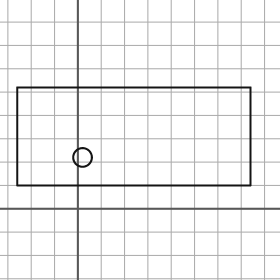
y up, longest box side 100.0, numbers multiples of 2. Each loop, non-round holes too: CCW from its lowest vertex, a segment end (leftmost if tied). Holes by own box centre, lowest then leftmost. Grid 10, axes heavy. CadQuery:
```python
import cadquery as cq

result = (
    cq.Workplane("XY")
    .moveTo(-26.0, 10.0)
    .lineTo(74.0, 10.0)
    .lineTo(74.0, 52.0)
    .lineTo(-26.0, 52.0)
    .close()
    .moveTo(2.0, 22.0)
    .circle(4.0)
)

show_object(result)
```